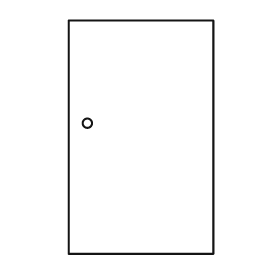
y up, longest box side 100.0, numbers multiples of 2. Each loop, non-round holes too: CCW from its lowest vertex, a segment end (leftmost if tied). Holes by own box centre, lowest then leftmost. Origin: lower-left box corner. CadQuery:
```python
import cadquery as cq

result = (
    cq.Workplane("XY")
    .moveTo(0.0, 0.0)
    .lineTo(62.0, 0.0)
    .lineTo(62.0, 100.0)
    .lineTo(0.0, 100.0)
    .close()
    .moveTo(8.0, 56.0)
    .circle(2.0)
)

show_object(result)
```